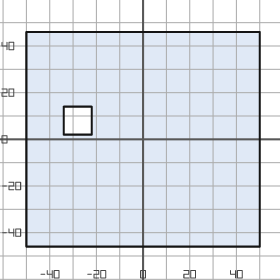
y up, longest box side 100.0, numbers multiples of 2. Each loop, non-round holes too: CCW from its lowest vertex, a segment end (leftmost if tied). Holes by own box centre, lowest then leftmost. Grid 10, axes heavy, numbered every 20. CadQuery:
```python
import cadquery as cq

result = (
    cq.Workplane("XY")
    .moveTo(-50.0, -46.0)
    .lineTo(50.0, -46.0)
    .lineTo(50.0, 46.0)
    .lineTo(-50.0, 46.0)
    .close()
    .moveTo(-34.0, 2.0)
    .lineTo(-22.0, 2.0)
    .lineTo(-22.0, 14.0)
    .lineTo(-34.0, 14.0)
    .close()
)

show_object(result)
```